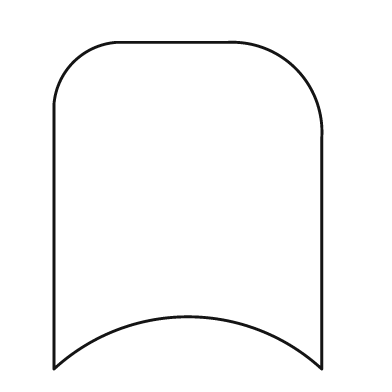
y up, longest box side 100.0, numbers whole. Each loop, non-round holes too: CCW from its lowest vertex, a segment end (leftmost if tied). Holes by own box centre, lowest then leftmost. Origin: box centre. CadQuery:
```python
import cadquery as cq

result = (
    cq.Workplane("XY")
    .moveTo(-41.0, -50.0)
    .threePointArc((0.0, -34.0), (41.0, -50.0))
    .lineTo(41.0, 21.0)
    .threePointArc((33.0, 42.0), (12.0, 50.0))
    .lineTo(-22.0, 50.0)
    .threePointArc((-35.0, 44.0), (-41.0, 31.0))
    .close()
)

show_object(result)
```